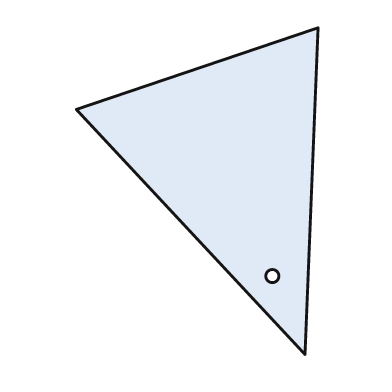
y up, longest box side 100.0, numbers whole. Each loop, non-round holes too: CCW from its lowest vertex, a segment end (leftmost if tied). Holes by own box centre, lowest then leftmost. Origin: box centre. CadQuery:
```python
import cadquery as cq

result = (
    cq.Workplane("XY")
    .moveTo(33.0, -50.0)
    .lineTo(37.0, 50.0)
    .lineTo(-37.0, 25.0)
    .close()
    .moveTo(23.0, -26.0)
    .circle(2.0)
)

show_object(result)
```